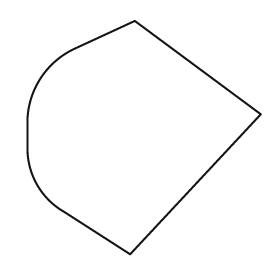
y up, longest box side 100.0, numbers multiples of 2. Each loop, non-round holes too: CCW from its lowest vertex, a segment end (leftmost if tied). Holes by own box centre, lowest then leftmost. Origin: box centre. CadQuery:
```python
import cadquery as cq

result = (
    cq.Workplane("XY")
    .moveTo(-6.0, -50.0)
    .lineTo(50.0, 10.0)
    .lineTo(-4.0, 50.0)
    .lineTo(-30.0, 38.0)
    .threePointArc((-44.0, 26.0), (-50.0, 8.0))
    .lineTo(-50.0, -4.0)
    .threePointArc((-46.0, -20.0), (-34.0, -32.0))
    .close()
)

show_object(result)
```